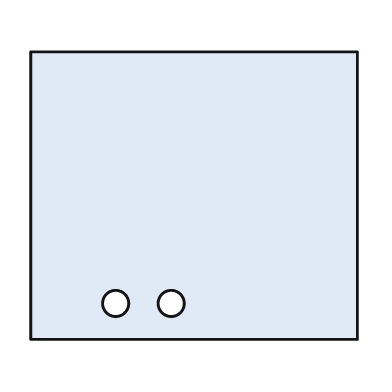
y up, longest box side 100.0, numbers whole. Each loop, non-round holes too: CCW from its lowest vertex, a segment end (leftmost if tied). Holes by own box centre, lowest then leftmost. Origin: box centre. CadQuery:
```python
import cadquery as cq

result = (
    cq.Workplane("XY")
    .moveTo(-50.0, -44.0)
    .lineTo(50.0, -44.0)
    .lineTo(50.0, 44.0)
    .lineTo(-50.0, 44.0)
    .close()
    .moveTo(-24.0, -33.0)
    .circle(4.0)
    .moveTo(-7.0, -33.0)
    .circle(4.0)
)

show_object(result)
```